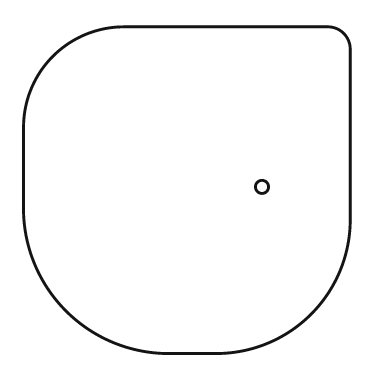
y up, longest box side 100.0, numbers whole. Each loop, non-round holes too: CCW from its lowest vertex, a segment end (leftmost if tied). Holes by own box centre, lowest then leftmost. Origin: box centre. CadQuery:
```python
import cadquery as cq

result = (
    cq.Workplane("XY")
    .moveTo(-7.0, -50.0)
    .lineTo(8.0, -50.0)
    .threePointArc((38.0, -38.0), (50.0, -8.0))
    .lineTo(50.0, 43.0)
    .threePointArc((48.0, 48.0), (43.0, 50.0))
    .lineTo(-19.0, 50.0)
    .threePointArc((-41.0, 41.0), (-50.0, 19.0))
    .lineTo(-50.0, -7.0)
    .threePointArc((-37.0, -37.0), (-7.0, -50.0))
    .close()
    .moveTo(23.0, 1.0)
    .circle(2.0)
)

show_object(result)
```